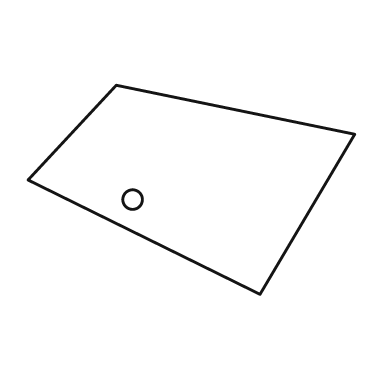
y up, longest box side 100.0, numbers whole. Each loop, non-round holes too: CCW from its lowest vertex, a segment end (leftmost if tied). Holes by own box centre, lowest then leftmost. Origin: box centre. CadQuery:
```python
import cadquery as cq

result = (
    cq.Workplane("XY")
    .moveTo(21.0, -32.0)
    .lineTo(50.0, 17.0)
    .lineTo(-23.0, 32.0)
    .lineTo(-50.0, 3.0)
    .close()
    .moveTo(-18.0, -3.0)
    .circle(3.0)
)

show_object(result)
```